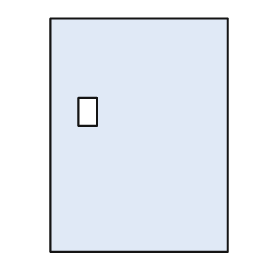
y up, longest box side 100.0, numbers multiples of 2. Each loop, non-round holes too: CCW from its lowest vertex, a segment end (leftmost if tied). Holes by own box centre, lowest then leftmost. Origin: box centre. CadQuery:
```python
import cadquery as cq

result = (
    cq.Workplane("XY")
    .moveTo(-38.0, -50.0)
    .lineTo(38.0, -50.0)
    .lineTo(38.0, 50.0)
    .lineTo(-38.0, 50.0)
    .close()
    .moveTo(-26.0, 4.0)
    .lineTo(-18.0, 4.0)
    .lineTo(-18.0, 16.0)
    .lineTo(-26.0, 16.0)
    .close()
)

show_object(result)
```